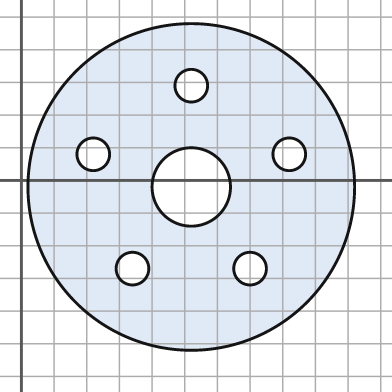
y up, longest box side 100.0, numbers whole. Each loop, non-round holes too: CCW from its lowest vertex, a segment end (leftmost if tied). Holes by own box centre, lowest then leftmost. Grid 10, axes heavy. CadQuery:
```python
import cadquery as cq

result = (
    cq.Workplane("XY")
    .moveTo(52.0, -2.0)
    .circle(50.0)
    .moveTo(34.0, -27.0)
    .circle(5.0)
    .moveTo(70.0, -27.0)
    .circle(5.0)
    .moveTo(52.0, -2.0)
    .circle(12.0)
    .moveTo(22.0, 8.0)
    .circle(5.0)
    .moveTo(82.0, 8.0)
    .circle(5.0)
    .moveTo(52.0, 29.0)
    .circle(5.0)
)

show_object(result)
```